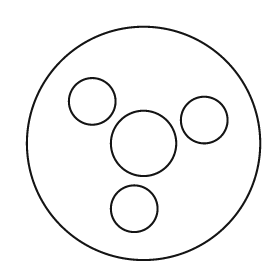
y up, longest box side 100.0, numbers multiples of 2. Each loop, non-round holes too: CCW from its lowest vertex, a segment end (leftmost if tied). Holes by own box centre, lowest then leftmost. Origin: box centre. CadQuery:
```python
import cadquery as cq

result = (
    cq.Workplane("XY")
    .moveTo(0.0, 0.0)
    .circle(50.0)
    .moveTo(-4.0, -28.0)
    .circle(10.0)
    .moveTo(0.0, 0.0)
    .circle(14.0)
    .moveTo(26.0, 10.0)
    .circle(10.0)
    .moveTo(-22.0, 18.0)
    .circle(10.0)
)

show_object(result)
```